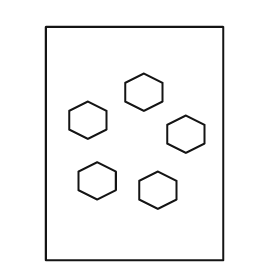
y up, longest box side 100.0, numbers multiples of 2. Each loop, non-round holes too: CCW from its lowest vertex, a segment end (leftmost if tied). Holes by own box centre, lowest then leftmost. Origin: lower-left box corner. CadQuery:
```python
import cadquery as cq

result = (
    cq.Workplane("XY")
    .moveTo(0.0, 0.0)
    .lineTo(76.0, 0.0)
    .lineTo(76.0, 100.0)
    .lineTo(0.0, 100.0)
    .close()
    .moveTo(48.0, 22.0)
    .lineTo(56.0, 26.0)
    .lineTo(56.0, 34.0)
    .lineTo(48.0, 38.0)
    .lineTo(40.0, 34.0)
    .lineTo(40.0, 26.0)
    .close()
    .moveTo(22.0, 26.0)
    .lineTo(30.0, 30.0)
    .lineTo(30.0, 38.0)
    .lineTo(22.0, 42.0)
    .lineTo(14.0, 38.0)
    .lineTo(14.0, 30.0)
    .close()
    .moveTo(60.0, 46.0)
    .lineTo(68.0, 50.0)
    .lineTo(68.0, 58.0)
    .lineTo(60.0, 62.0)
    .lineTo(52.0, 58.0)
    .lineTo(52.0, 50.0)
    .close()
    .moveTo(18.0, 52.0)
    .lineTo(26.0, 56.0)
    .lineTo(26.0, 64.0)
    .lineTo(18.0, 68.0)
    .lineTo(10.0, 64.0)
    .lineTo(10.0, 56.0)
    .close()
    .moveTo(42.0, 64.0)
    .lineTo(50.0, 68.0)
    .lineTo(50.0, 76.0)
    .lineTo(42.0, 80.0)
    .lineTo(34.0, 76.0)
    .lineTo(34.0, 68.0)
    .close()
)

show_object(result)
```